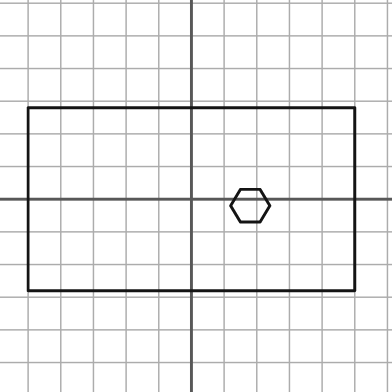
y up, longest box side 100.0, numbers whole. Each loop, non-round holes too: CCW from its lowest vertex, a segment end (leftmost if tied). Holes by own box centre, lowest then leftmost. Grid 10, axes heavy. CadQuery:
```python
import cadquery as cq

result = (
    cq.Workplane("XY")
    .moveTo(-50.0, -28.0)
    .lineTo(50.0, -28.0)
    .lineTo(50.0, 28.0)
    .lineTo(-50.0, 28.0)
    .close()
    .moveTo(15.0, -7.0)
    .lineTo(21.0, -7.0)
    .lineTo(24.0, -2.0)
    .lineTo(21.0, 3.0)
    .lineTo(15.0, 3.0)
    .lineTo(12.0, -2.0)
    .close()
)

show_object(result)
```